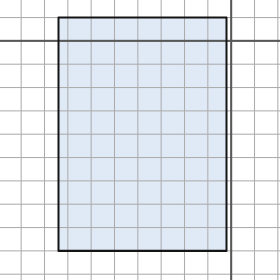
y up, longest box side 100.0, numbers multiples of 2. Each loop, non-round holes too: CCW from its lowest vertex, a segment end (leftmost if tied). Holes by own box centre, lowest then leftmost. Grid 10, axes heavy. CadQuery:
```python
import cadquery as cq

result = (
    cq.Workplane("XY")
    .moveTo(-74.0, -90.0)
    .lineTo(-2.0, -90.0)
    .lineTo(-2.0, 10.0)
    .lineTo(-74.0, 10.0)
    .close()
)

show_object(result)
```